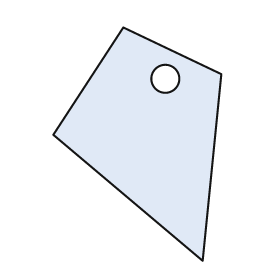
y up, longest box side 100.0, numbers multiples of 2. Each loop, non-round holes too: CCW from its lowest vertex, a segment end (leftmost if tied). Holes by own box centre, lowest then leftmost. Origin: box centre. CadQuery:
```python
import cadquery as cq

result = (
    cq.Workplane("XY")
    .moveTo(28.0, -50.0)
    .lineTo(36.0, 30.0)
    .lineTo(-6.0, 50.0)
    .lineTo(-36.0, 4.0)
    .close()
    .moveTo(12.0, 28.0)
    .circle(6.0)
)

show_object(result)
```